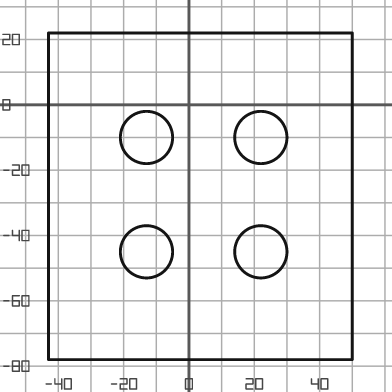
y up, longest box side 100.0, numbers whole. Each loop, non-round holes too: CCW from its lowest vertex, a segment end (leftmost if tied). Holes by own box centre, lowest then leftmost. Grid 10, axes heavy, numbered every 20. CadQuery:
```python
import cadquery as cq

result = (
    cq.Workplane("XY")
    .moveTo(-43.0, -78.0)
    .lineTo(50.0, -78.0)
    .lineTo(50.0, 22.0)
    .lineTo(-43.0, 22.0)
    .close()
    .moveTo(-13.0, -45.0)
    .circle(8.0)
    .moveTo(22.0, -45.0)
    .circle(8.0)
    .moveTo(-13.0, -10.0)
    .circle(8.0)
    .moveTo(22.0, -10.0)
    .circle(8.0)
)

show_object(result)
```